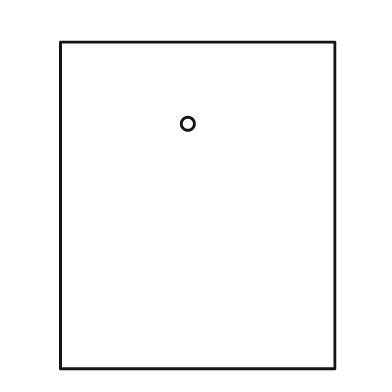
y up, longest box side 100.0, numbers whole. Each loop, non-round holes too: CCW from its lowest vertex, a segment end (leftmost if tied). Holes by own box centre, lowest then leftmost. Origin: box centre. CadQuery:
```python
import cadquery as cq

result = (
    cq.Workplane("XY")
    .moveTo(-42.0, -50.0)
    .lineTo(42.0, -50.0)
    .lineTo(42.0, 50.0)
    .lineTo(-42.0, 50.0)
    .close()
    .moveTo(-3.0, 25.0)
    .circle(2.0)
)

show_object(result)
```